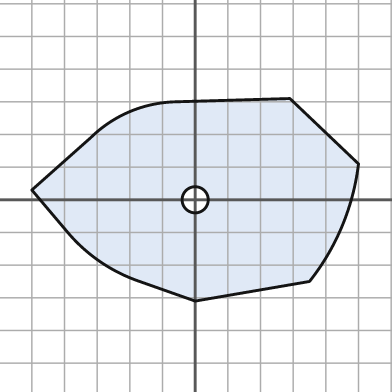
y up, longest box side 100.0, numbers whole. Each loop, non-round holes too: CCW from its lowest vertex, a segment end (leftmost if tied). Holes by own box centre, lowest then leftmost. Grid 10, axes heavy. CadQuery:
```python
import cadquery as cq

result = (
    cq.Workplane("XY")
    .moveTo(0.0, -31.0)
    .lineTo(35.0, -25.0)
    .threePointArc((45.0, -8.0), (50.0, 11.0))
    .lineTo(29.0, 31.0)
    .lineTo(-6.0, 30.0)
    .threePointArc((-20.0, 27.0), (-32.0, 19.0))
    .lineTo(-50.0, 3.0)
    .lineTo(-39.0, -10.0)
    .threePointArc((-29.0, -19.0), (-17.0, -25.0))
    .close()
    .moveTo(0.0, 0.0)
    .circle(4.0)
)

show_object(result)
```